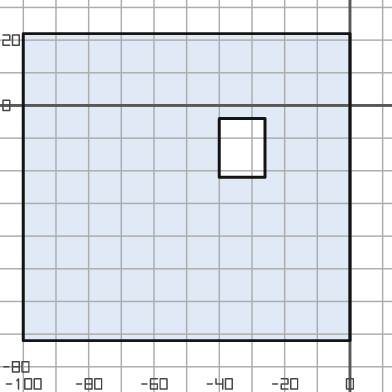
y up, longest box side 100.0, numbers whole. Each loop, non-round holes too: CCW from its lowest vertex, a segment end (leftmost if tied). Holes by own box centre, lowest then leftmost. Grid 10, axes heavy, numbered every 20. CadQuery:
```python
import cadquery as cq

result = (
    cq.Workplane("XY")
    .moveTo(-100.0, -72.0)
    .lineTo(0.0, -72.0)
    .lineTo(0.0, 22.0)
    .lineTo(-100.0, 22.0)
    .close()
    .moveTo(-40.0, -22.0)
    .lineTo(-26.0, -22.0)
    .lineTo(-26.0, -4.0)
    .lineTo(-40.0, -4.0)
    .close()
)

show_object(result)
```